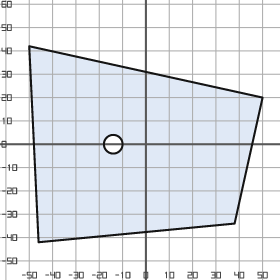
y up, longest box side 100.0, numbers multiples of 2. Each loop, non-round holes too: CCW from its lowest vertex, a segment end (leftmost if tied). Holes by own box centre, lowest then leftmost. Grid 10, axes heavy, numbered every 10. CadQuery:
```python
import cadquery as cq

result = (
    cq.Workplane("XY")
    .moveTo(-46.0, -42.0)
    .lineTo(38.0, -34.0)
    .lineTo(50.0, 20.0)
    .lineTo(-50.0, 42.0)
    .close()
    .moveTo(-14.0, 0.0)
    .circle(4.0)
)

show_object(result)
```